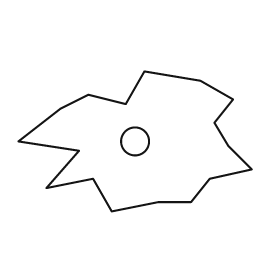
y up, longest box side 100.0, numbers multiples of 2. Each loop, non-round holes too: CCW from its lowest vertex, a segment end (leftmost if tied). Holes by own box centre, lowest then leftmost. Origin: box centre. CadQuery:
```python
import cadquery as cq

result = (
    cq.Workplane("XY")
    .moveTo(-10.0, -30.0)
    .lineTo(10.0, -26.0)
    .lineTo(24.0, -26.0)
    .lineTo(32.0, -16.0)
    .lineTo(50.0, -12.0)
    .lineTo(40.0, -2.0)
    .lineTo(34.0, 8.0)
    .lineTo(42.0, 18.0)
    .lineTo(28.0, 26.0)
    .lineTo(4.0, 30.0)
    .lineTo(-4.0, 16.0)
    .lineTo(-20.0, 20.0)
    .lineTo(-32.0, 14.0)
    .lineTo(-50.0, 0.0)
    .lineTo(-24.0, -4.0)
    .lineTo(-38.0, -20.0)
    .lineTo(-18.0, -16.0)
    .close()
    .moveTo(0.0, 0.0)
    .circle(6.0)
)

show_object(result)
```